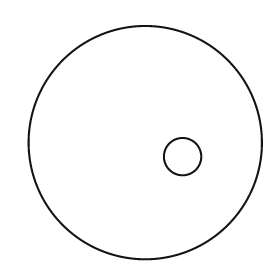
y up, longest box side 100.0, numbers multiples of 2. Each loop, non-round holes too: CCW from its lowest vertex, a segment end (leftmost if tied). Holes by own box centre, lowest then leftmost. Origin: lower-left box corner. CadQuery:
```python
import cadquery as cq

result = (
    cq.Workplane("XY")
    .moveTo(50.0, 50.0)
    .circle(50.0)
    .moveTo(66.0, 44.0)
    .circle(8.0)
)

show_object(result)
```